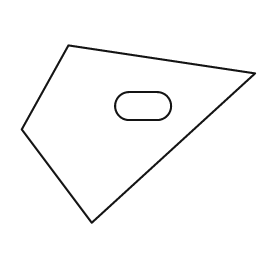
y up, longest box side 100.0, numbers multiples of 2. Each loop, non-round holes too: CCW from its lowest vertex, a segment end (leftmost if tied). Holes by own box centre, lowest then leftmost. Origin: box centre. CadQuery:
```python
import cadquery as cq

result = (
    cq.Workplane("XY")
    .moveTo(-20.0, -38.0)
    .lineTo(50.0, 26.0)
    .lineTo(-30.0, 38.0)
    .lineTo(-50.0, 2.0)
    .close()
    .moveTo(-4.0, 6.0)
    .lineTo(8.0, 6.0)
    .threePointArc((14.0, 12.0), (8.0, 18.0))
    .lineTo(-4.0, 18.0)
    .threePointArc((-10.0, 12.0), (-4.0, 6.0))
    .close()
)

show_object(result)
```